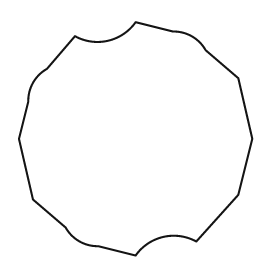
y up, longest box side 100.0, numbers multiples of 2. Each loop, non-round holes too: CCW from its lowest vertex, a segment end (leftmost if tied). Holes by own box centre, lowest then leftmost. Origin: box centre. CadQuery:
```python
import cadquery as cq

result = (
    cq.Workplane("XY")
    .moveTo(0.0, -50.0)
    .threePointArc((12.0, -42.0), (26.0, -44.0))
    .lineTo(44.0, -24.0)
    .lineTo(50.0, 0.0)
    .lineTo(44.0, 26.0)
    .lineTo(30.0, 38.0)
    .threePointArc((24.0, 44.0), (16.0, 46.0))
    .lineTo(0.0, 50.0)
    .threePointArc((-12.0, 42.0), (-26.0, 44.0))
    .lineTo(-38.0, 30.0)
    .threePointArc((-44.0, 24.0), (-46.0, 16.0))
    .lineTo(-50.0, 0.0)
    .lineTo(-44.0, -26.0)
    .lineTo(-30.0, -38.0)
    .threePointArc((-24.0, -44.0), (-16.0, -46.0))
    .close()
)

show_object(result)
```